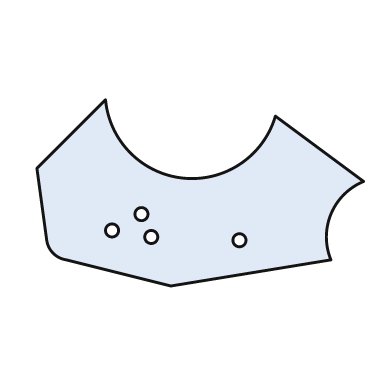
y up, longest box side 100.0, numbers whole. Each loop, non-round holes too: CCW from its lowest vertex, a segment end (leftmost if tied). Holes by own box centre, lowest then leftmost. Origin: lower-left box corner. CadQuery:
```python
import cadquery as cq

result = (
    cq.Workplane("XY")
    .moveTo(41.0, 0.0)
    .lineTo(90.0, 8.0)
    .threePointArc((90.0, 22.0), (100.0, 32.0))
    .lineTo(73.0, 52.0)
    .threePointArc((45.0, 33.0), (21.0, 57.0))
    .lineTo(0.0, 36.0)
    .lineTo(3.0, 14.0)
    .threePointArc((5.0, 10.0), (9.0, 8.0))
    .close()
    .moveTo(62.0, 14.0)
    .circle(2.0)
    .moveTo(35.0, 15.0)
    .circle(2.0)
    .moveTo(23.0, 17.0)
    .circle(2.0)
    .moveTo(32.0, 22.0)
    .circle(2.0)
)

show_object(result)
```